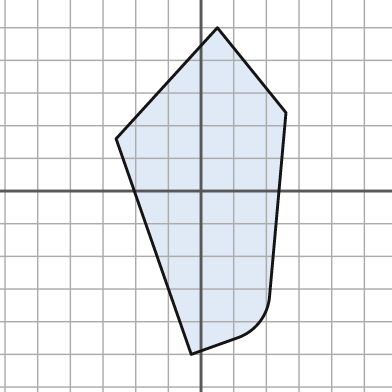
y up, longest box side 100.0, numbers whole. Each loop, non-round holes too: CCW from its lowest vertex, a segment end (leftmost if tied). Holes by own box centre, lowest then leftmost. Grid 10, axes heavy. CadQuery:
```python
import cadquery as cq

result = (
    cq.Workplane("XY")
    .moveTo(-3.0, -50.0)
    .lineTo(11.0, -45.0)
    .threePointArc((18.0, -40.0), (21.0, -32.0))
    .lineTo(26.0, 24.0)
    .lineTo(5.0, 50.0)
    .lineTo(-26.0, 16.0)
    .close()
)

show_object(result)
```